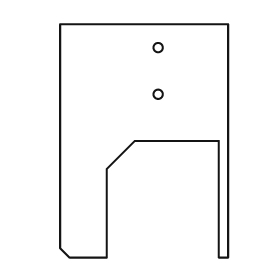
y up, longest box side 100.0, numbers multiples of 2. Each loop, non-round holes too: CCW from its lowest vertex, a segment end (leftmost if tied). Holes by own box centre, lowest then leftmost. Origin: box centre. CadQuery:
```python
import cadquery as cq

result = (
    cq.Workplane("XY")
    .moveTo(-32.0, -50.0)
    .lineTo(-16.0, -50.0)
    .lineTo(-16.0, -12.0)
    .lineTo(-4.0, 0.0)
    .lineTo(32.0, 0.0)
    .lineTo(32.0, -50.0)
    .lineTo(36.0, -50.0)
    .lineTo(36.0, 50.0)
    .lineTo(-36.0, 50.0)
    .lineTo(-36.0, -46.0)
    .close()
    .moveTo(6.0, 20.0)
    .circle(2.0)
    .moveTo(6.0, 40.0)
    .circle(2.0)
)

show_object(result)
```